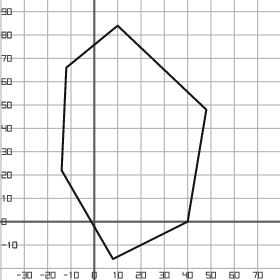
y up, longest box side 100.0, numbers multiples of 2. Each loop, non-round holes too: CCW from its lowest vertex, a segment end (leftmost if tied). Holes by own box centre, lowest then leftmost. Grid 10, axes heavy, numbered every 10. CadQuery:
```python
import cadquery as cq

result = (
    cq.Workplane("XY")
    .moveTo(8.0, -16.0)
    .lineTo(40.0, 0.0)
    .lineTo(48.0, 48.0)
    .lineTo(10.0, 84.0)
    .lineTo(-12.0, 66.0)
    .lineTo(-14.0, 22.0)
    .close()
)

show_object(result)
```